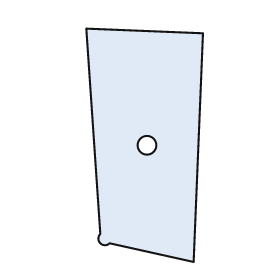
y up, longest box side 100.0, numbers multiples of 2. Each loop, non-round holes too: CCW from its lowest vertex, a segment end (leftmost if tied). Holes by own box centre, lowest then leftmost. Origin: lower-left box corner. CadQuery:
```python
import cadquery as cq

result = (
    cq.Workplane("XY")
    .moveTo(46.0, 0.0)
    .lineTo(50.0, 98.0)
    .lineTo(0.0, 100.0)
    .lineTo(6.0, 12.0)
    .threePointArc((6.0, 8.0), (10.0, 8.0))
    .close()
    .moveTo(26.0, 50.0)
    .circle(4.0)
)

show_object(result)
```